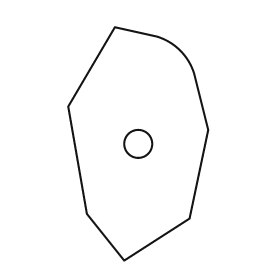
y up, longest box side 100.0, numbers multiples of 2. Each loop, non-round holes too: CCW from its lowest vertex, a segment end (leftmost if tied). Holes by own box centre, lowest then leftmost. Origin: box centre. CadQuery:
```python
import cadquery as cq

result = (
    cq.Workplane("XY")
    .moveTo(-6.0, -50.0)
    .lineTo(22.0, -32.0)
    .lineTo(30.0, 6.0)
    .lineTo(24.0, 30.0)
    .threePointArc((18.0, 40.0), (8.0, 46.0))
    .lineTo(-10.0, 50.0)
    .lineTo(-30.0, 16.0)
    .lineTo(-22.0, -30.0)
    .close()
    .moveTo(0.0, 0.0)
    .circle(6.0)
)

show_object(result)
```